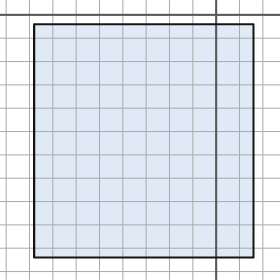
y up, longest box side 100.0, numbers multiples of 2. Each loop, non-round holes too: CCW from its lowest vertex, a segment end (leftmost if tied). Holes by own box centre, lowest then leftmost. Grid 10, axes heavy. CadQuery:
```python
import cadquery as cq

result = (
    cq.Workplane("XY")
    .moveTo(-78.0, -104.0)
    .lineTo(16.0, -104.0)
    .lineTo(16.0, -4.0)
    .lineTo(-78.0, -4.0)
    .close()
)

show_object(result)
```